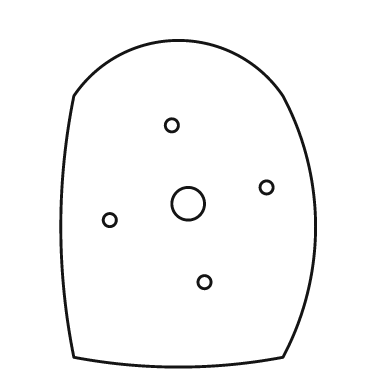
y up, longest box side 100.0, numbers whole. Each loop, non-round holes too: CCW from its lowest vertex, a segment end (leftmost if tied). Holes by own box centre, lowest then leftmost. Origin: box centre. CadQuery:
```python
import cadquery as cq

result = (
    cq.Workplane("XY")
    .moveTo(-35.0, -47.0)
    .threePointArc((-3.0, -50.0), (29.0, -47.0))
    .threePointArc((39.0, -7.0), (29.0, 33.0))
    .threePointArc((-3.0, 50.0), (-35.0, 33.0))
    .threePointArc((-39.0, -7.0), (-35.0, -47.0))
    .close()
    .moveTo(5.0, -24.0)
    .circle(2.0)
    .moveTo(-24.0, -5.0)
    .circle(2.0)
    .moveTo(0.0, 0.0)
    .circle(5.0)
    .moveTo(24.0, 5.0)
    .circle(2.0)
    .moveTo(-5.0, 24.0)
    .circle(2.0)
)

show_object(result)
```